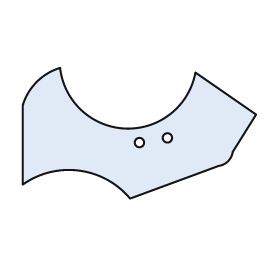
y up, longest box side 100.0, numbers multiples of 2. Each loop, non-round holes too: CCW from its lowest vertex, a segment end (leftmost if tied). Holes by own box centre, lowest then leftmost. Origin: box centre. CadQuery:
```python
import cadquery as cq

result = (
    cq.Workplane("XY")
    .moveTo(-4.0, -28.0)
    .lineTo(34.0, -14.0)
    .threePointArc((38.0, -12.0), (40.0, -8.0))
    .lineTo(50.0, 8.0)
    .lineTo(24.0, 26.0)
    .threePointArc((-6.0, 2.0), (-34.0, 28.0))
    .threePointArc((-44.0, 22.0), (-50.0, 12.0))
    .lineTo(-50.0, -22.0)
    .threePointArc((-26.0, -16.0), (-4.0, -28.0))
    .close()
    .moveTo(0.0, -4.0)
    .circle(2.0)
    .moveTo(12.0, -2.0)
    .circle(2.0)
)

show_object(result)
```